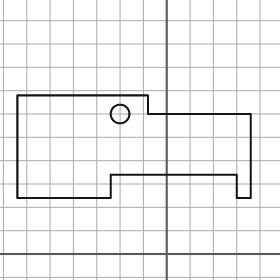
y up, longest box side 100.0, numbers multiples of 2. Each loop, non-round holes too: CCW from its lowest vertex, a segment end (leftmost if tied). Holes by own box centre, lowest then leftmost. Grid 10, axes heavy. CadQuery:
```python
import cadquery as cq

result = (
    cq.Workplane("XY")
    .moveTo(-64.0, 24.0)
    .lineTo(-24.0, 24.0)
    .lineTo(-24.0, 34.0)
    .lineTo(30.0, 34.0)
    .lineTo(30.0, 24.0)
    .lineTo(36.0, 24.0)
    .lineTo(36.0, 60.0)
    .lineTo(-8.0, 60.0)
    .lineTo(-8.0, 68.0)
    .lineTo(-64.0, 68.0)
    .close()
    .moveTo(-20.0, 60.0)
    .circle(4.0)
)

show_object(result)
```